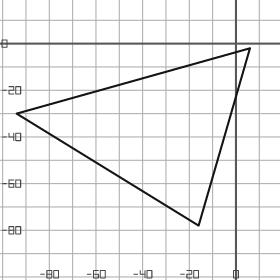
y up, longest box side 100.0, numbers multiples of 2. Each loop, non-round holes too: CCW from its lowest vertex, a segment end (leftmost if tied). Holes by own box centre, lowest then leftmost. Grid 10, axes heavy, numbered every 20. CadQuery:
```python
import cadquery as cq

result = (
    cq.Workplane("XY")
    .moveTo(-16.0, -78.0)
    .lineTo(6.0, -2.0)
    .lineTo(-94.0, -30.0)
    .close()
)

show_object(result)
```